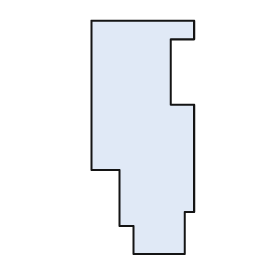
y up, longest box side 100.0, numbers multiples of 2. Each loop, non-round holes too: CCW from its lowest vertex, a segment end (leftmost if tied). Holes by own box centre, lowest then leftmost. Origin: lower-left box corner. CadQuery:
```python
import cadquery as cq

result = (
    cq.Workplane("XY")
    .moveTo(18.0, 0.0)
    .lineTo(40.0, 0.0)
    .lineTo(40.0, 18.0)
    .lineTo(44.0, 18.0)
    .lineTo(44.0, 64.0)
    .lineTo(34.0, 64.0)
    .lineTo(34.0, 92.0)
    .lineTo(44.0, 92.0)
    .lineTo(44.0, 100.0)
    .lineTo(0.0, 100.0)
    .lineTo(0.0, 36.0)
    .lineTo(12.0, 36.0)
    .lineTo(12.0, 12.0)
    .lineTo(18.0, 12.0)
    .close()
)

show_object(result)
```